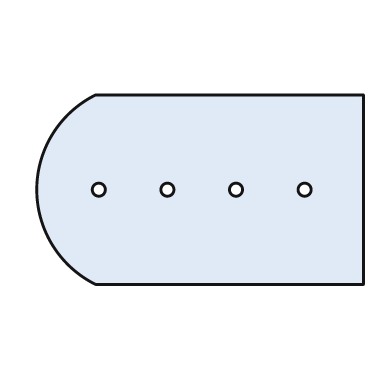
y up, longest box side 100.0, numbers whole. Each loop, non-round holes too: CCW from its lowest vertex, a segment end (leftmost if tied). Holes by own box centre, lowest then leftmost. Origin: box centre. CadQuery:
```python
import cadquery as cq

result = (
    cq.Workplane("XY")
    .moveTo(-32.0, -29.0)
    .lineTo(50.0, -29.0)
    .lineTo(50.0, 29.0)
    .lineTo(-32.0, 29.0)
    .threePointArc((-50.0, 0.0), (-32.0, -29.0))
    .close()
    .moveTo(-31.0, 0.0)
    .circle(2.0)
    .moveTo(-10.0, 0.0)
    .circle(2.0)
    .moveTo(11.0, 0.0)
    .circle(2.0)
    .moveTo(32.0, 0.0)
    .circle(2.0)
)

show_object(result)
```